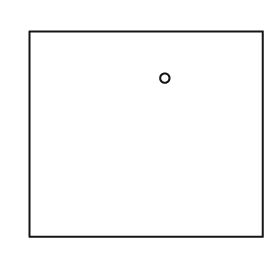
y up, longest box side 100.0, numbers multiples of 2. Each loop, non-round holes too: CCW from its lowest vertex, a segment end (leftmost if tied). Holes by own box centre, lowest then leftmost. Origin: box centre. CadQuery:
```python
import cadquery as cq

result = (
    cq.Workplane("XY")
    .moveTo(-50.0, -44.0)
    .lineTo(50.0, -44.0)
    .lineTo(50.0, 44.0)
    .lineTo(-50.0, 44.0)
    .close()
    .moveTo(8.0, 24.0)
    .circle(2.0)
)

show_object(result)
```